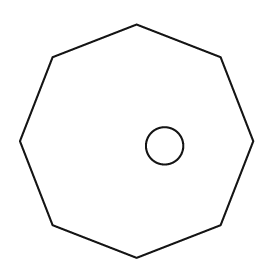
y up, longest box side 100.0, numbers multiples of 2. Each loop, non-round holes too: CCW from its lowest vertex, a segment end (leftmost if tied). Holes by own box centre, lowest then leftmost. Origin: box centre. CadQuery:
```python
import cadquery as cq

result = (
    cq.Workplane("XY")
    .moveTo(0.0, -50.0)
    .lineTo(36.0, -36.0)
    .lineTo(50.0, 0.0)
    .lineTo(36.0, 36.0)
    .lineTo(0.0, 50.0)
    .lineTo(-36.0, 36.0)
    .lineTo(-50.0, 0.0)
    .lineTo(-36.0, -36.0)
    .close()
    .moveTo(12.0, -2.0)
    .circle(8.0)
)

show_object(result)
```